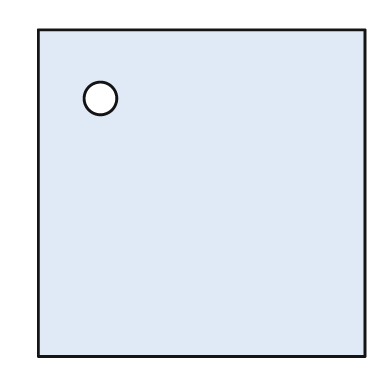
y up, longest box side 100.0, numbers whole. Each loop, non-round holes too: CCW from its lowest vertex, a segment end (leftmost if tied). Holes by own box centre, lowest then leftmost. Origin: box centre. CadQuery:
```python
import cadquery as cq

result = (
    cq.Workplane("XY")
    .moveTo(-50.0, -50.0)
    .lineTo(50.0, -50.0)
    .lineTo(50.0, 50.0)
    .lineTo(-50.0, 50.0)
    .close()
    .moveTo(-31.0, 29.0)
    .circle(5.0)
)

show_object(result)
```